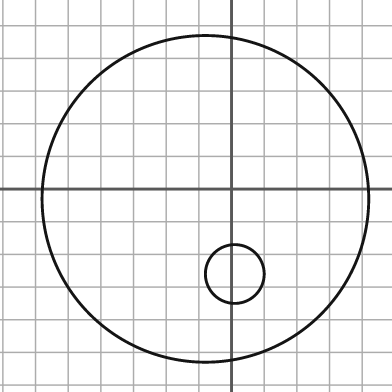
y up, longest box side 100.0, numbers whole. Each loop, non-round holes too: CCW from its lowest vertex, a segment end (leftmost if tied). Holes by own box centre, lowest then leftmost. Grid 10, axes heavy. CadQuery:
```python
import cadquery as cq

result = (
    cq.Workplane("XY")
    .moveTo(-8.0, -3.0)
    .circle(50.0)
    .moveTo(1.0, -26.0)
    .circle(9.0)
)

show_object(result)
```